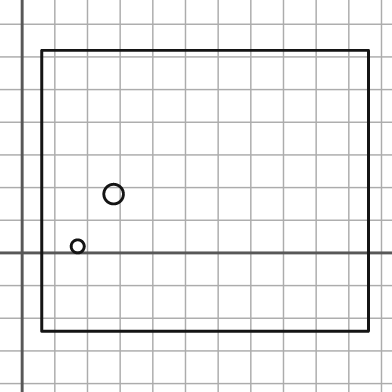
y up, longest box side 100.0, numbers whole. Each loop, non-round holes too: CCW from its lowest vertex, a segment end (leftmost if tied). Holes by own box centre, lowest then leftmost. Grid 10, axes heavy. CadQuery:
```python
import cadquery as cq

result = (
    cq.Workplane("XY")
    .moveTo(6.0, -24.0)
    .lineTo(106.0, -24.0)
    .lineTo(106.0, 62.0)
    .lineTo(6.0, 62.0)
    .close()
    .moveTo(17.0, 2.0)
    .circle(2.0)
    .moveTo(28.0, 18.0)
    .circle(3.0)
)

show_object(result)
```